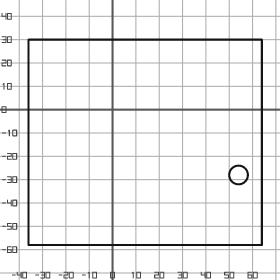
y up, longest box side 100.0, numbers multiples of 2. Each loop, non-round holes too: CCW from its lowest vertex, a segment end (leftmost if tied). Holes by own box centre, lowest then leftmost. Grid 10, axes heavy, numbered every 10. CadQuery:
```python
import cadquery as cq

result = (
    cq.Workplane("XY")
    .moveTo(-36.0, -58.0)
    .lineTo(64.0, -58.0)
    .lineTo(64.0, 30.0)
    .lineTo(-36.0, 30.0)
    .close()
    .moveTo(54.0, -28.0)
    .circle(4.0)
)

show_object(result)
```